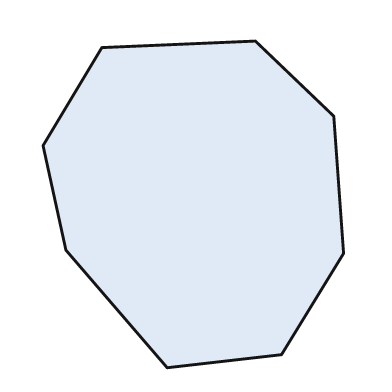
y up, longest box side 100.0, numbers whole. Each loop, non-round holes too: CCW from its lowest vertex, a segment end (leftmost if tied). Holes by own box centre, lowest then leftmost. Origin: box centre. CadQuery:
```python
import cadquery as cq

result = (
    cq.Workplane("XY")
    .moveTo(-8.0, -50.0)
    .lineTo(27.0, -46.0)
    .lineTo(46.0, -15.0)
    .lineTo(43.0, 27.0)
    .lineTo(19.0, 50.0)
    .lineTo(-28.0, 48.0)
    .lineTo(-46.0, 18.0)
    .lineTo(-39.0, -14.0)
    .close()
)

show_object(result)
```